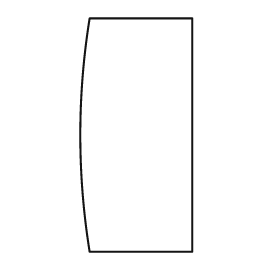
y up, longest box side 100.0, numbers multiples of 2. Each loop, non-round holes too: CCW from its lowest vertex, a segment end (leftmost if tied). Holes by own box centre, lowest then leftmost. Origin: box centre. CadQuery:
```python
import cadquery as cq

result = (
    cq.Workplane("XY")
    .moveTo(-20.0, -50.0)
    .lineTo(24.0, -50.0)
    .lineTo(24.0, 50.0)
    .lineTo(-20.0, 50.0)
    .threePointArc((-24.0, 0.0), (-20.0, -50.0))
    .close()
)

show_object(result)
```